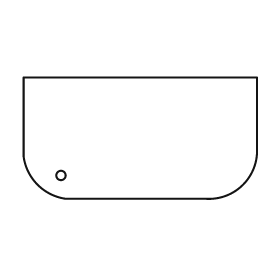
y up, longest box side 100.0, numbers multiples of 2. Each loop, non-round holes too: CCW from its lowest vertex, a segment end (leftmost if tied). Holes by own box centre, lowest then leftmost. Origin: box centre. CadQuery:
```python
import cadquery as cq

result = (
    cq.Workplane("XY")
    .moveTo(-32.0, -26.0)
    .lineTo(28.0, -26.0)
    .threePointArc((44.0, -20.0), (50.0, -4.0))
    .lineTo(50.0, 26.0)
    .lineTo(-50.0, 26.0)
    .lineTo(-50.0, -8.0)
    .threePointArc((-44.0, -20.0), (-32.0, -26.0))
    .close()
    .moveTo(-34.0, -16.0)
    .circle(2.0)
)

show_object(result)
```